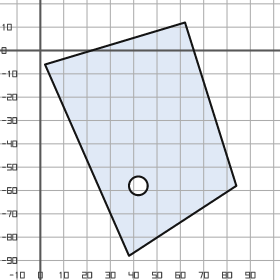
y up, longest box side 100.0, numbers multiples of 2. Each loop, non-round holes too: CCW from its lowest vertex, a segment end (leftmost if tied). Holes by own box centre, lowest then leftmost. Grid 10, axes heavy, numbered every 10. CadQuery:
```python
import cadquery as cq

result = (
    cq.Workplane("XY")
    .moveTo(38.0, -88.0)
    .lineTo(84.0, -58.0)
    .lineTo(62.0, 12.0)
    .lineTo(2.0, -6.0)
    .close()
    .moveTo(42.0, -58.0)
    .circle(4.0)
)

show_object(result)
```